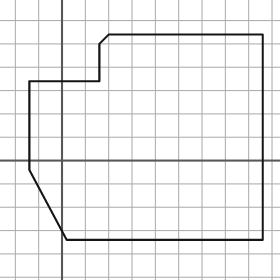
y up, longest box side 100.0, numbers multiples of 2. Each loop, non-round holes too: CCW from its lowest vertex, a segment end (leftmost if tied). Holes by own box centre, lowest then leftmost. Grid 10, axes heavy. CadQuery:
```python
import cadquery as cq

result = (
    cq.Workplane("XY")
    .moveTo(2.0, -34.0)
    .lineTo(86.0, -34.0)
    .lineTo(86.0, 54.0)
    .lineTo(20.0, 54.0)
    .lineTo(16.0, 50.0)
    .lineTo(16.0, 34.0)
    .lineTo(-14.0, 34.0)
    .lineTo(-14.0, -4.0)
    .close()
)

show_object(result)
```